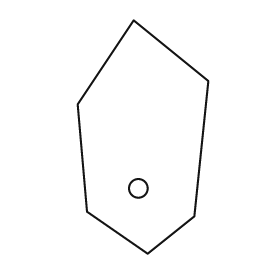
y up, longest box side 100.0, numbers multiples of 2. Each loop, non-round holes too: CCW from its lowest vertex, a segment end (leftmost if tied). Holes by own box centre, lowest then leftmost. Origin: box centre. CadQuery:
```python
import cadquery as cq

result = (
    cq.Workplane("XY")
    .moveTo(2.0, -50.0)
    .lineTo(22.0, -34.0)
    .lineTo(28.0, 24.0)
    .lineTo(-4.0, 50.0)
    .lineTo(-28.0, 14.0)
    .lineTo(-24.0, -32.0)
    .close()
    .moveTo(-2.0, -22.0)
    .circle(4.0)
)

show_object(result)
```